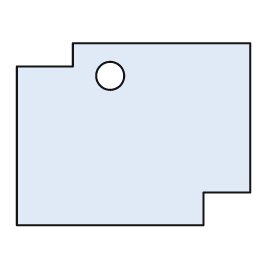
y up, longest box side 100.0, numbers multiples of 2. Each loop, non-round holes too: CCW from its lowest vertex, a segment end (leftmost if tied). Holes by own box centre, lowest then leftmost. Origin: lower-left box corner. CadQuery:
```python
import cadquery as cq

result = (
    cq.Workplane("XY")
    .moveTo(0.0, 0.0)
    .lineTo(80.0, 0.0)
    .lineTo(80.0, 14.0)
    .lineTo(100.0, 14.0)
    .lineTo(100.0, 78.0)
    .lineTo(24.0, 78.0)
    .lineTo(24.0, 68.0)
    .lineTo(0.0, 68.0)
    .close()
    .moveTo(40.0, 64.0)
    .circle(6.0)
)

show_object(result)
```